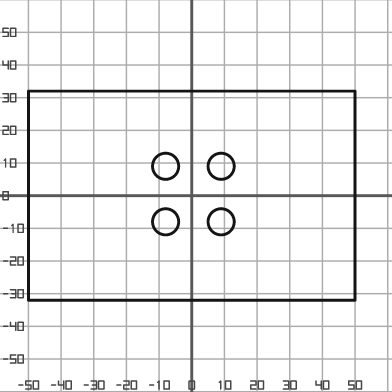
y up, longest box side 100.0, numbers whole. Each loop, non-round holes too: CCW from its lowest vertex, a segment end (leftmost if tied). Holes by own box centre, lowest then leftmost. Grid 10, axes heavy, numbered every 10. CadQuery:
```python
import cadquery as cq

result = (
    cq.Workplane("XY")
    .moveTo(-50.0, -32.0)
    .lineTo(50.0, -32.0)
    .lineTo(50.0, 32.0)
    .lineTo(-50.0, 32.0)
    .close()
    .moveTo(-8.0, -8.0)
    .circle(4.0)
    .moveTo(9.0, -8.0)
    .circle(4.0)
    .moveTo(-8.0, 9.0)
    .circle(4.0)
    .moveTo(9.0, 9.0)
    .circle(4.0)
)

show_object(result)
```